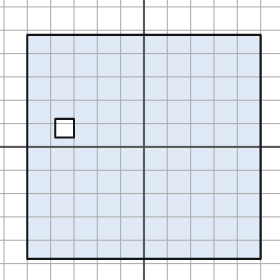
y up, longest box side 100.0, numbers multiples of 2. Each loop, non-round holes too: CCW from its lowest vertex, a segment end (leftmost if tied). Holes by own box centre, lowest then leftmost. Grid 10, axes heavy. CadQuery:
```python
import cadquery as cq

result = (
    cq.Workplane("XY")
    .moveTo(-50.0, -48.0)
    .lineTo(50.0, -48.0)
    .lineTo(50.0, 48.0)
    .lineTo(-50.0, 48.0)
    .close()
    .moveTo(-38.0, 4.0)
    .lineTo(-30.0, 4.0)
    .lineTo(-30.0, 12.0)
    .lineTo(-38.0, 12.0)
    .close()
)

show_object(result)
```